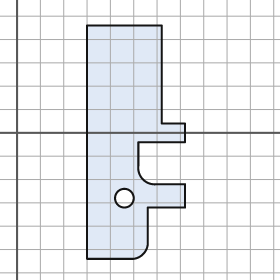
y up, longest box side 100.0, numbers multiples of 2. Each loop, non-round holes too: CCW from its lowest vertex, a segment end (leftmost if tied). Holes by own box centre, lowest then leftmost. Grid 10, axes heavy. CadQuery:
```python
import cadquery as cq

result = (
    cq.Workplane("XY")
    .moveTo(30.0, -54.0)
    .lineTo(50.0, -54.0)
    .threePointArc((54.0, -52.0), (56.0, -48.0))
    .lineTo(56.0, -32.0)
    .lineTo(72.0, -32.0)
    .lineTo(72.0, -22.0)
    .lineTo(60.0, -22.0)
    .threePointArc((54.0, -20.0), (52.0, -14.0))
    .lineTo(52.0, -4.0)
    .lineTo(72.0, -4.0)
    .lineTo(72.0, 4.0)
    .lineTo(62.0, 4.0)
    .lineTo(62.0, 46.0)
    .lineTo(30.0, 46.0)
    .close()
    .moveTo(46.0, -28.0)
    .circle(4.0)
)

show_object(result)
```